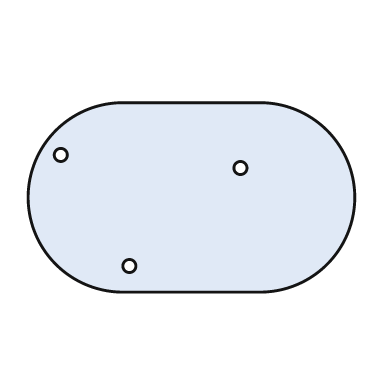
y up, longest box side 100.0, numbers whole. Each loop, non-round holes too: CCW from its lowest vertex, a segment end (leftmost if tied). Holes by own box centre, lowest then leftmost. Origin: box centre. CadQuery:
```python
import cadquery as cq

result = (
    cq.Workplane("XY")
    .moveTo(-21.0, -29.0)
    .lineTo(21.0, -29.0)
    .threePointArc((50.0, 0.0), (21.0, 29.0))
    .lineTo(-21.0, 29.0)
    .threePointArc((-50.0, 0.0), (-21.0, -29.0))
    .close()
    .moveTo(-19.0, -21.0)
    .circle(2.0)
    .moveTo(15.0, 9.0)
    .circle(2.0)
    .moveTo(-40.0, 13.0)
    .circle(2.0)
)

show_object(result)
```